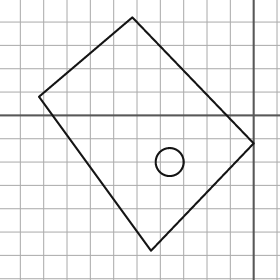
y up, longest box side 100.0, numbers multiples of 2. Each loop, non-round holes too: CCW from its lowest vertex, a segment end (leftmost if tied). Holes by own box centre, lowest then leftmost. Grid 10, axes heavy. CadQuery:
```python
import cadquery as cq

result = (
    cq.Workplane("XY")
    .moveTo(-44.0, -58.0)
    .lineTo(0.0, -12.0)
    .lineTo(-52.0, 42.0)
    .lineTo(-92.0, 8.0)
    .close()
    .moveTo(-36.0, -20.0)
    .circle(6.0)
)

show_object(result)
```